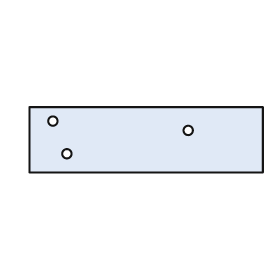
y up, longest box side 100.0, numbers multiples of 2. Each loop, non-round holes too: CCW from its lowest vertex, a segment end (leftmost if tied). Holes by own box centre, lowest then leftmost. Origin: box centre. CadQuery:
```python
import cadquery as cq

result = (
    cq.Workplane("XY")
    .moveTo(-50.0, -14.0)
    .lineTo(50.0, -14.0)
    .lineTo(50.0, 14.0)
    .lineTo(-50.0, 14.0)
    .close()
    .moveTo(-34.0, -6.0)
    .circle(2.0)
    .moveTo(18.0, 4.0)
    .circle(2.0)
    .moveTo(-40.0, 8.0)
    .circle(2.0)
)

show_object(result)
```